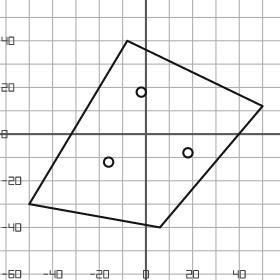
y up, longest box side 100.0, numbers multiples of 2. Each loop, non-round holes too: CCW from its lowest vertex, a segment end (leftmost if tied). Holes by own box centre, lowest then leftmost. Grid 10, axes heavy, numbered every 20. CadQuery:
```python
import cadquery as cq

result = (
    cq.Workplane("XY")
    .moveTo(6.0, -40.0)
    .lineTo(50.0, 12.0)
    .lineTo(-8.0, 40.0)
    .lineTo(-50.0, -30.0)
    .close()
    .moveTo(-16.0, -12.0)
    .circle(2.0)
    .moveTo(18.0, -8.0)
    .circle(2.0)
    .moveTo(-2.0, 18.0)
    .circle(2.0)
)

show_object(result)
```